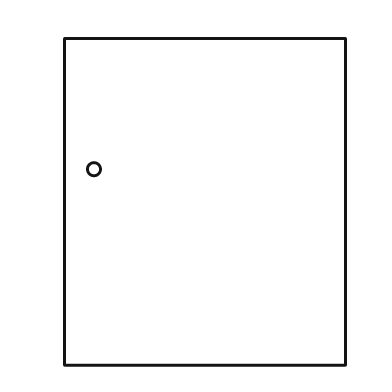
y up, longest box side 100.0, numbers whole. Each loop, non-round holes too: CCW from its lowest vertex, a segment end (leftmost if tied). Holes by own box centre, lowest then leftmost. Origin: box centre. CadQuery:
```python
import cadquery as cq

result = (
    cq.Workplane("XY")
    .moveTo(-43.0, -50.0)
    .lineTo(43.0, -50.0)
    .lineTo(43.0, 50.0)
    .lineTo(-43.0, 50.0)
    .close()
    .moveTo(-34.0, 10.0)
    .circle(2.0)
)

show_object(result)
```